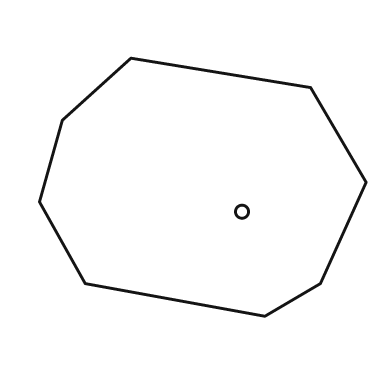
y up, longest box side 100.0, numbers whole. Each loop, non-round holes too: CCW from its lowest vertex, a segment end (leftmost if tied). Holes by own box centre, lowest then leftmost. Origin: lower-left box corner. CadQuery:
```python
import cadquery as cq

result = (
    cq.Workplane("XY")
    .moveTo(69.0, 0.0)
    .lineTo(86.0, 10.0)
    .lineTo(100.0, 41.0)
    .lineTo(83.0, 70.0)
    .lineTo(28.0, 79.0)
    .lineTo(7.0, 60.0)
    .lineTo(0.0, 35.0)
    .lineTo(14.0, 10.0)
    .close()
    .moveTo(62.0, 32.0)
    .circle(2.0)
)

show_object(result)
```